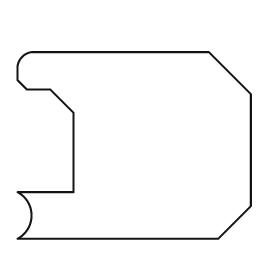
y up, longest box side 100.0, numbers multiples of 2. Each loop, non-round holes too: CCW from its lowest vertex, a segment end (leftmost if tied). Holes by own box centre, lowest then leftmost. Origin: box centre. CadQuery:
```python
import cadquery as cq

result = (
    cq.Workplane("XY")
    .moveTo(-50.0, -40.0)
    .lineTo(36.0, -40.0)
    .lineTo(50.0, -26.0)
    .lineTo(50.0, 22.0)
    .lineTo(32.0, 40.0)
    .lineTo(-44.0, 40.0)
    .threePointArc((-48.0, 38.0), (-50.0, 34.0))
    .lineTo(-50.0, 28.0)
    .lineTo(-46.0, 24.0)
    .lineTo(-36.0, 24.0)
    .lineTo(-26.0, 14.0)
    .lineTo(-26.0, -20.0)
    .lineTo(-50.0, -20.0)
    .threePointArc((-44.0, -30.0), (-50.0, -40.0))
    .close()
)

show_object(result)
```